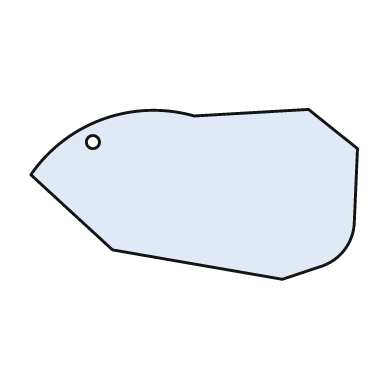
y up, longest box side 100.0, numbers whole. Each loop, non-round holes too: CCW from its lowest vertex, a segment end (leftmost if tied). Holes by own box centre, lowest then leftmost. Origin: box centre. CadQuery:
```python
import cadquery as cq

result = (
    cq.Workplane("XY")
    .moveTo(27.0, -26.0)
    .lineTo(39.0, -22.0)
    .threePointArc((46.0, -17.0), (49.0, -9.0))
    .lineTo(50.0, 14.0)
    .lineTo(35.0, 26.0)
    .lineTo(0.0, 24.0)
    .threePointArc((-28.0, 23.0), (-50.0, 6.0))
    .lineTo(-25.0, -17.0)
    .close()
    .moveTo(-31.0, 16.0)
    .circle(2.0)
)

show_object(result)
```